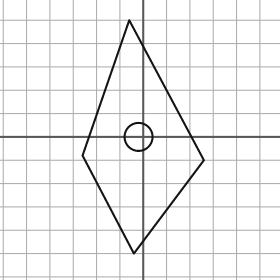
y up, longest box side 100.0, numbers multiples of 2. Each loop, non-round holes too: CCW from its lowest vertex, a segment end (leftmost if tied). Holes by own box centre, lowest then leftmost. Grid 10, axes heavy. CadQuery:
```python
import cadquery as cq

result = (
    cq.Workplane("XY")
    .moveTo(-4.0, -50.0)
    .lineTo(26.0, -10.0)
    .lineTo(-6.0, 50.0)
    .lineTo(-26.0, -8.0)
    .close()
    .moveTo(-2.0, 0.0)
    .circle(6.0)
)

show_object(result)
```